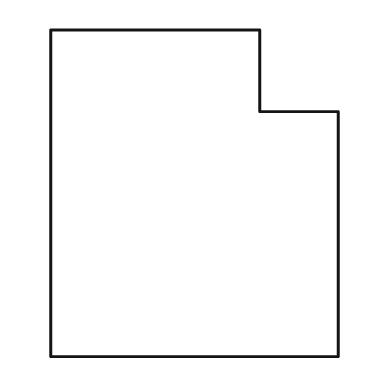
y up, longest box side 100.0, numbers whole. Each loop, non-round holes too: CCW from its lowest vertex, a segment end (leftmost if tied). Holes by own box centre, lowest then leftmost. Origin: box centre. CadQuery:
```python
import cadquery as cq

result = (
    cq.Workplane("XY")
    .moveTo(-44.0, -50.0)
    .lineTo(44.0, -50.0)
    .lineTo(44.0, 25.0)
    .lineTo(20.0, 25.0)
    .lineTo(20.0, 50.0)
    .lineTo(-44.0, 50.0)
    .close()
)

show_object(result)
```